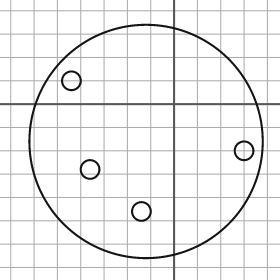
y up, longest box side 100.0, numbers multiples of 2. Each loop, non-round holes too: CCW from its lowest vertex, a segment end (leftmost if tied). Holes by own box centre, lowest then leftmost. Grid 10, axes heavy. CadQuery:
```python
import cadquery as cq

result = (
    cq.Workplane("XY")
    .moveTo(-12.0, -16.0)
    .circle(50.0)
    .moveTo(-14.0, -46.0)
    .circle(4.0)
    .moveTo(-36.0, -28.0)
    .circle(4.0)
    .moveTo(30.0, -20.0)
    .circle(4.0)
    .moveTo(-44.0, 10.0)
    .circle(4.0)
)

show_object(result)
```